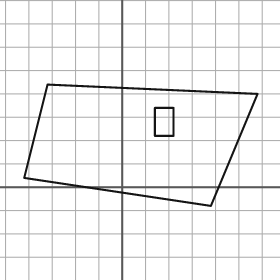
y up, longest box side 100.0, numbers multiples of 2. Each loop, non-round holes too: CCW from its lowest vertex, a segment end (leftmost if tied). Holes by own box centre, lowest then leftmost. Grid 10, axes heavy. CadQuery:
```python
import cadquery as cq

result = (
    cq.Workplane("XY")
    .moveTo(38.0, -8.0)
    .lineTo(58.0, 40.0)
    .lineTo(-32.0, 44.0)
    .lineTo(-42.0, 4.0)
    .close()
    .moveTo(14.0, 22.0)
    .lineTo(22.0, 22.0)
    .lineTo(22.0, 34.0)
    .lineTo(14.0, 34.0)
    .close()
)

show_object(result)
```